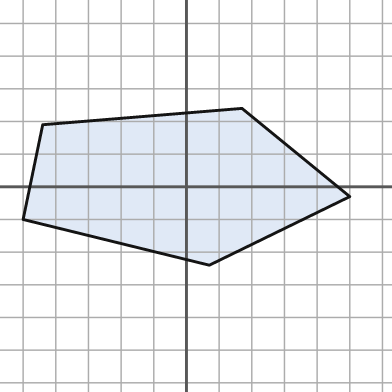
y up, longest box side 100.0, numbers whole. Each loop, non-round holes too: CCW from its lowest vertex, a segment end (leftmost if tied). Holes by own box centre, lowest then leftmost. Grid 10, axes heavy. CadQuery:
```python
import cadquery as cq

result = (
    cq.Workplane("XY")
    .moveTo(7.0, -24.0)
    .lineTo(50.0, -3.0)
    .lineTo(17.0, 24.0)
    .lineTo(-44.0, 19.0)
    .lineTo(-50.0, -10.0)
    .close()
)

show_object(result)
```